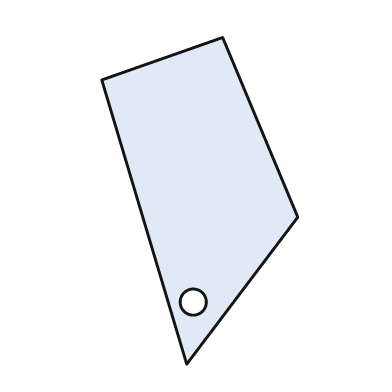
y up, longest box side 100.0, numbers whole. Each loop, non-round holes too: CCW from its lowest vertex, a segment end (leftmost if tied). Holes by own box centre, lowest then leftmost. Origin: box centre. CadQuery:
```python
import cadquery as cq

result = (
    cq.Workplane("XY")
    .moveTo(-4.0, -50.0)
    .lineTo(30.0, -5.0)
    .lineTo(7.0, 50.0)
    .lineTo(-30.0, 37.0)
    .close()
    .moveTo(-2.0, -31.0)
    .circle(4.0)
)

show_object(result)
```